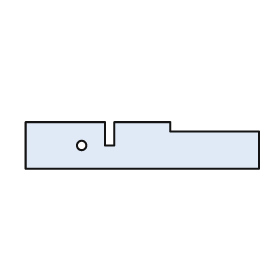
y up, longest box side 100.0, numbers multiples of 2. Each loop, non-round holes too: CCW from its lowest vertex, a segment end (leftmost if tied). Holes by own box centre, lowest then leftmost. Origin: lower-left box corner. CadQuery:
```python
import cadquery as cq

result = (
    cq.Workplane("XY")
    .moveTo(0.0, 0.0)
    .lineTo(100.0, 0.0)
    .lineTo(100.0, 16.0)
    .lineTo(62.0, 16.0)
    .lineTo(62.0, 20.0)
    .lineTo(38.0, 20.0)
    .lineTo(38.0, 10.0)
    .lineTo(34.0, 10.0)
    .lineTo(34.0, 20.0)
    .lineTo(0.0, 20.0)
    .close()
    .moveTo(24.0, 10.0)
    .circle(2.0)
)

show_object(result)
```